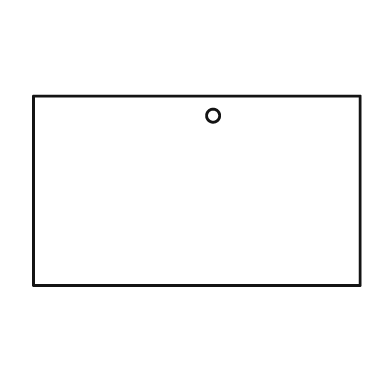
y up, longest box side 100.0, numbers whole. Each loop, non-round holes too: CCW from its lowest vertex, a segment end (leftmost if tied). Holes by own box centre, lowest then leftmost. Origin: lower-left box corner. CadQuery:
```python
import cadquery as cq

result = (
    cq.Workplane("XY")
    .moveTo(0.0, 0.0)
    .lineTo(100.0, 0.0)
    .lineTo(100.0, 58.0)
    .lineTo(0.0, 58.0)
    .close()
    .moveTo(55.0, 52.0)
    .circle(2.0)
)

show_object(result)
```